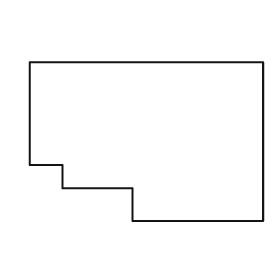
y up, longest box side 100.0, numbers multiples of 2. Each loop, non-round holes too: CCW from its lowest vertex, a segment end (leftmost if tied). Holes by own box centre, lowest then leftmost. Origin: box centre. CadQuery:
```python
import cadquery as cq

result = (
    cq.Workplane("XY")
    .moveTo(-6.0, -34.0)
    .lineTo(50.0, -34.0)
    .lineTo(50.0, 34.0)
    .lineTo(-50.0, 34.0)
    .lineTo(-50.0, -10.0)
    .lineTo(-36.0, -10.0)
    .lineTo(-36.0, -20.0)
    .lineTo(-6.0, -20.0)
    .close()
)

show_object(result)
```